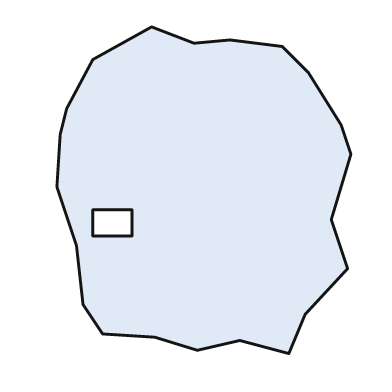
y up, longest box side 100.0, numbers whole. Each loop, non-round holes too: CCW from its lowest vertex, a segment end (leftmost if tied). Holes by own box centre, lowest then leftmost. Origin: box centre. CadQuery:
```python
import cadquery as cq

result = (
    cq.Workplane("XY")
    .moveTo(26.0, -50.0)
    .lineTo(31.0, -38.0)
    .lineTo(44.0, -24.0)
    .lineTo(39.0, -9.0)
    .lineTo(45.0, 11.0)
    .lineTo(42.0, 20.0)
    .lineTo(32.0, 36.0)
    .lineTo(24.0, 44.0)
    .lineTo(8.0, 46.0)
    .lineTo(-3.0, 45.0)
    .lineTo(-16.0, 50.0)
    .lineTo(-34.0, 40.0)
    .lineTo(-42.0, 25.0)
    .lineTo(-44.0, 17.0)
    .lineTo(-45.0, 1.0)
    .lineTo(-39.0, -17.0)
    .lineTo(-37.0, -35.0)
    .lineTo(-31.0, -44.0)
    .lineTo(-15.0, -45.0)
    .lineTo(-2.0, -49.0)
    .lineTo(11.0, -46.0)
    .close()
    .moveTo(-34.0, -14.0)
    .lineTo(-22.0, -14.0)
    .lineTo(-22.0, -6.0)
    .lineTo(-34.0, -6.0)
    .close()
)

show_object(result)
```